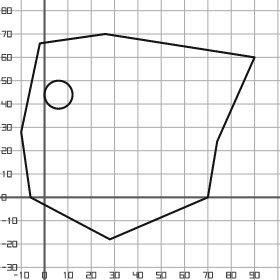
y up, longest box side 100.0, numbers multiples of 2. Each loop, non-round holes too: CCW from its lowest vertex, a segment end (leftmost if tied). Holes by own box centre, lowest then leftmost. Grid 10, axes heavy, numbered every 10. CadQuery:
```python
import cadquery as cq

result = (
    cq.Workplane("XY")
    .moveTo(28.0, -18.0)
    .lineTo(70.0, 0.0)
    .lineTo(74.0, 24.0)
    .lineTo(90.0, 60.0)
    .lineTo(26.0, 70.0)
    .lineTo(-2.0, 66.0)
    .lineTo(-10.0, 28.0)
    .lineTo(-6.0, 0.0)
    .close()
    .moveTo(6.0, 44.0)
    .circle(6.0)
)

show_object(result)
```